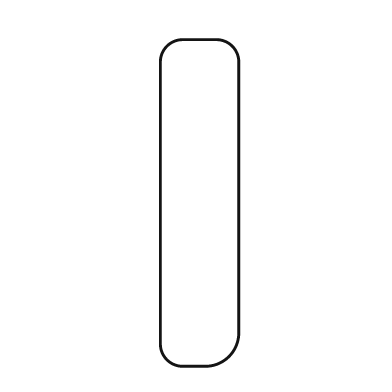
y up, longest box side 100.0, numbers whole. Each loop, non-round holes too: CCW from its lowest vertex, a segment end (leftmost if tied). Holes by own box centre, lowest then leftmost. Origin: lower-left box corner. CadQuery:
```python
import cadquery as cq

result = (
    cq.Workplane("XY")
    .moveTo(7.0, 0.0)
    .lineTo(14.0, 0.0)
    .threePointArc((21.0, 3.0), (24.0, 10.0))
    .lineTo(24.0, 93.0)
    .threePointArc((22.0, 98.0), (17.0, 100.0))
    .lineTo(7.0, 100.0)
    .threePointArc((2.0, 98.0), (0.0, 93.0))
    .lineTo(0.0, 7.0)
    .threePointArc((2.0, 2.0), (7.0, 0.0))
    .close()
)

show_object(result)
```